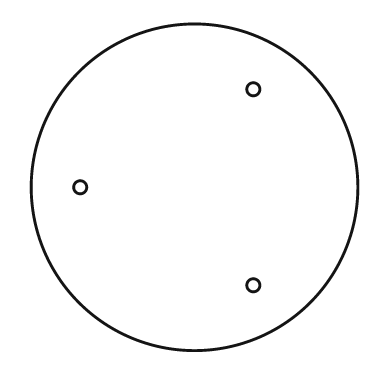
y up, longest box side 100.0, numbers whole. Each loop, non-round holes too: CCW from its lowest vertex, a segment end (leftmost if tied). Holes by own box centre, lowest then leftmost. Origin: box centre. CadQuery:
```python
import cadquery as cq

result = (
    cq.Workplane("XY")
    .moveTo(0.0, 0.0)
    .circle(50.0)
    .moveTo(18.0, -30.0)
    .circle(2.0)
    .moveTo(-35.0, 0.0)
    .circle(2.0)
    .moveTo(18.0, 30.0)
    .circle(2.0)
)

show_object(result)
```